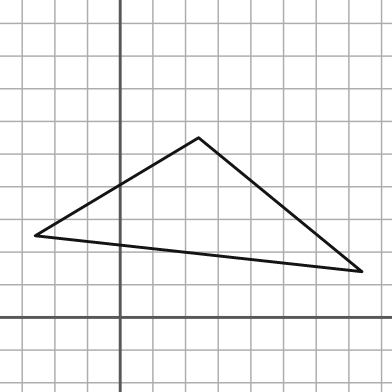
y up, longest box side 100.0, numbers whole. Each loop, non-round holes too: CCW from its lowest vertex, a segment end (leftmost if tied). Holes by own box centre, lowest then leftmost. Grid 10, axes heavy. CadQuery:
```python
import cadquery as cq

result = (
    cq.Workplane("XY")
    .moveTo(74.0, 14.0)
    .lineTo(24.0, 55.0)
    .lineTo(-26.0, 25.0)
    .close()
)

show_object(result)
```